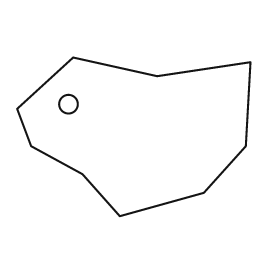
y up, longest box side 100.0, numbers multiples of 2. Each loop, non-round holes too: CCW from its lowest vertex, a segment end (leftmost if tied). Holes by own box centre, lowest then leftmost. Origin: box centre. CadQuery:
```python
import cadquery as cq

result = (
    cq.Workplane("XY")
    .moveTo(-6.0, -34.0)
    .lineTo(30.0, -24.0)
    .lineTo(48.0, -4.0)
    .lineTo(50.0, 32.0)
    .lineTo(10.0, 26.0)
    .lineTo(-26.0, 34.0)
    .lineTo(-50.0, 12.0)
    .lineTo(-44.0, -4.0)
    .lineTo(-22.0, -16.0)
    .close()
    .moveTo(-28.0, 14.0)
    .circle(4.0)
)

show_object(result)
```